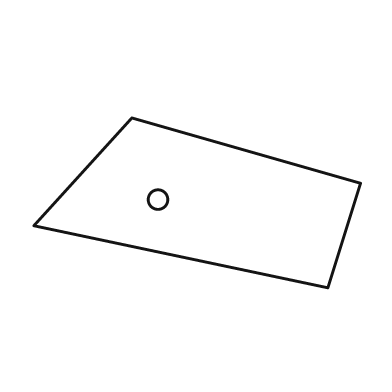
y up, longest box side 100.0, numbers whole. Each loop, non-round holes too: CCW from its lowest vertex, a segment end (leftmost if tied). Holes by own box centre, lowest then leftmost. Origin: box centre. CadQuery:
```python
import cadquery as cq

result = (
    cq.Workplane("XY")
    .moveTo(40.0, -26.0)
    .lineTo(50.0, 6.0)
    .lineTo(-20.0, 26.0)
    .lineTo(-50.0, -7.0)
    .close()
    .moveTo(-12.0, 1.0)
    .circle(3.0)
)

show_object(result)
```